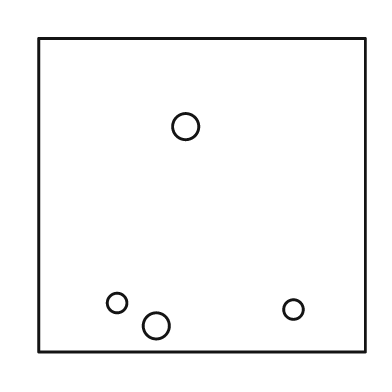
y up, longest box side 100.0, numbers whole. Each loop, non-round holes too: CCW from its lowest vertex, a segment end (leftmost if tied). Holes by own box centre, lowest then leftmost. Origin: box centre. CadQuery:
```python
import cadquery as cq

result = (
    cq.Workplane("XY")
    .moveTo(-50.0, -48.0)
    .lineTo(50.0, -48.0)
    .lineTo(50.0, 48.0)
    .lineTo(-50.0, 48.0)
    .close()
    .moveTo(-14.0, -40.0)
    .circle(4.0)
    .moveTo(28.0, -35.0)
    .circle(3.0)
    .moveTo(-26.0, -33.0)
    .circle(3.0)
    .moveTo(-5.0, 21.0)
    .circle(4.0)
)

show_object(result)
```